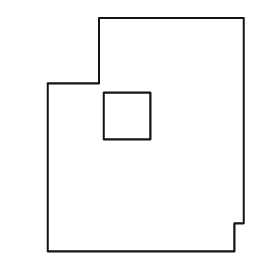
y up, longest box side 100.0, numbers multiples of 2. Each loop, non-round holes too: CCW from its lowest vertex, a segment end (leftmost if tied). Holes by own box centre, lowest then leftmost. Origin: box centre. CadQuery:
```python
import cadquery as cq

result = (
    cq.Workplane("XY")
    .moveTo(-42.0, -50.0)
    .lineTo(38.0, -50.0)
    .lineTo(38.0, -38.0)
    .lineTo(42.0, -38.0)
    .lineTo(42.0, 50.0)
    .lineTo(-20.0, 50.0)
    .lineTo(-20.0, 22.0)
    .lineTo(-42.0, 22.0)
    .close()
    .moveTo(-18.0, -2.0)
    .lineTo(2.0, -2.0)
    .lineTo(2.0, 18.0)
    .lineTo(-18.0, 18.0)
    .close()
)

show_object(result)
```